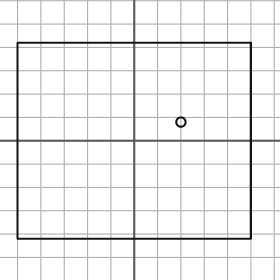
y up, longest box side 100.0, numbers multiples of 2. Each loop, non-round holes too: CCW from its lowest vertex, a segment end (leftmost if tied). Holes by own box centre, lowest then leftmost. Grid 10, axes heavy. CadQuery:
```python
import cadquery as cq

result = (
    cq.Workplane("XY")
    .moveTo(-50.0, -42.0)
    .lineTo(50.0, -42.0)
    .lineTo(50.0, 42.0)
    .lineTo(-50.0, 42.0)
    .close()
    .moveTo(20.0, 8.0)
    .circle(2.0)
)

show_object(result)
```